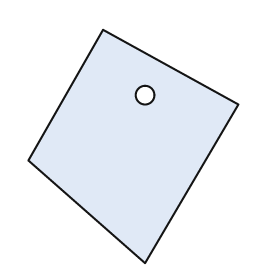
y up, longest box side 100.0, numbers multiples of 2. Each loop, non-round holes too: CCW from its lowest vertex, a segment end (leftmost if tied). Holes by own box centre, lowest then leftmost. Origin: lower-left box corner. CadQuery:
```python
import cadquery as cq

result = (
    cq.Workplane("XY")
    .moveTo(50.0, 0.0)
    .lineTo(90.0, 68.0)
    .lineTo(32.0, 100.0)
    .lineTo(0.0, 44.0)
    .close()
    .moveTo(50.0, 72.0)
    .circle(4.0)
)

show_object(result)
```